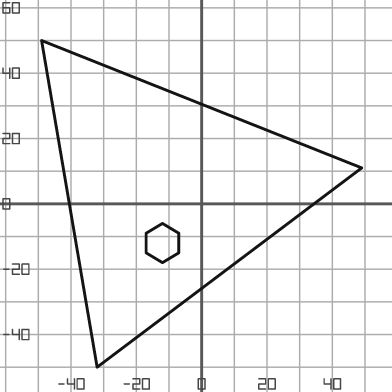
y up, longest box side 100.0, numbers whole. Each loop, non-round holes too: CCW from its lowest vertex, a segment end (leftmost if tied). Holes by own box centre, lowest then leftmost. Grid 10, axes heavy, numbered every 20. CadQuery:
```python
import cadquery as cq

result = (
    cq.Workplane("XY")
    .moveTo(-32.0, -50.0)
    .lineTo(49.0, 11.0)
    .lineTo(-49.0, 50.0)
    .close()
    .moveTo(-12.0, -18.0)
    .lineTo(-7.0, -15.0)
    .lineTo(-7.0, -9.0)
    .lineTo(-12.0, -6.0)
    .lineTo(-17.0, -9.0)
    .lineTo(-17.0, -15.0)
    .close()
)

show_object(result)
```